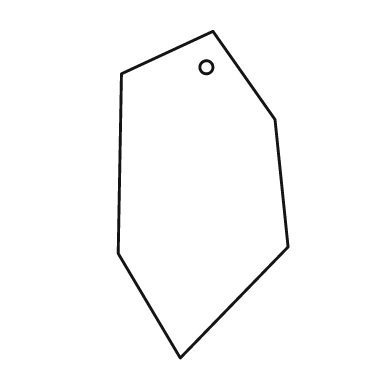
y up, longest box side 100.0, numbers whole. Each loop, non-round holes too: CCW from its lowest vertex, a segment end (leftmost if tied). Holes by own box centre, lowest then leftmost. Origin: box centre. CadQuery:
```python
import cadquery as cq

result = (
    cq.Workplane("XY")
    .moveTo(-7.0, -50.0)
    .lineTo(26.0, -16.0)
    .lineTo(22.0, 23.0)
    .lineTo(3.0, 50.0)
    .lineTo(-25.0, 37.0)
    .lineTo(-26.0, -18.0)
    .close()
    .moveTo(1.0, 39.0)
    .circle(2.0)
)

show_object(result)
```